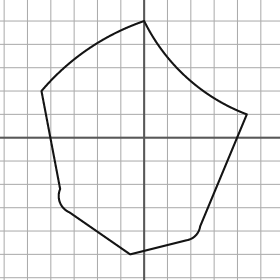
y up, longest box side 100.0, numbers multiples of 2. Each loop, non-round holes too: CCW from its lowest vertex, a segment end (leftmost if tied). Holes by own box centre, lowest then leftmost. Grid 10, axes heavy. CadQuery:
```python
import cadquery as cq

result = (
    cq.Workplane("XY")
    .moveTo(-6.0, -50.0)
    .lineTo(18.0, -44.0)
    .threePointArc((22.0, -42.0), (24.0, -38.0))
    .lineTo(44.0, 10.0)
    .threePointArc((18.0, 26.0), (0.0, 50.0))
    .threePointArc((-24.0, 38.0), (-44.0, 20.0))
    .lineTo(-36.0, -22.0)
    .threePointArc((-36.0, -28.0), (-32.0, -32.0))
    .close()
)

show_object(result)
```